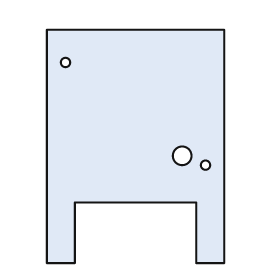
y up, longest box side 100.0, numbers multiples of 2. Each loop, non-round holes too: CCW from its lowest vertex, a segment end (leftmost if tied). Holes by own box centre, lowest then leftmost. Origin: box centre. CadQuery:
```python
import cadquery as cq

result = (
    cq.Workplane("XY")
    .moveTo(-38.0, -50.0)
    .lineTo(-26.0, -50.0)
    .lineTo(-26.0, -24.0)
    .lineTo(26.0, -24.0)
    .lineTo(26.0, -50.0)
    .lineTo(38.0, -50.0)
    .lineTo(38.0, 50.0)
    .lineTo(-38.0, 50.0)
    .close()
    .moveTo(30.0, -8.0)
    .circle(2.0)
    .moveTo(20.0, -4.0)
    .circle(4.0)
    .moveTo(-30.0, 36.0)
    .circle(2.0)
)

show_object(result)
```